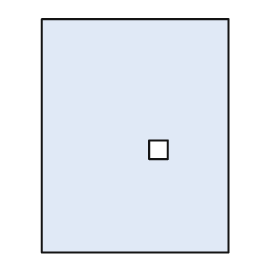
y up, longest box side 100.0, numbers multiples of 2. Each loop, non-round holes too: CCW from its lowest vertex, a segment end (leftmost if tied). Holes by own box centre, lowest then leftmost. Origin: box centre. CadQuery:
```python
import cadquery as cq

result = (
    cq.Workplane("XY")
    .moveTo(-40.0, -50.0)
    .lineTo(40.0, -50.0)
    .lineTo(40.0, 50.0)
    .lineTo(-40.0, 50.0)
    .close()
    .moveTo(6.0, -10.0)
    .lineTo(14.0, -10.0)
    .lineTo(14.0, -2.0)
    .lineTo(6.0, -2.0)
    .close()
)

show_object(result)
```